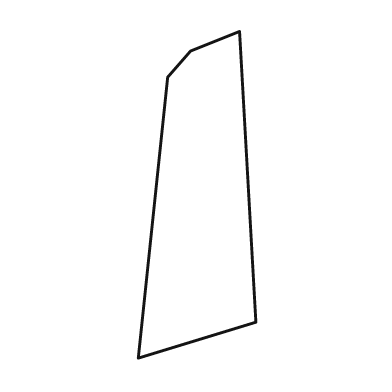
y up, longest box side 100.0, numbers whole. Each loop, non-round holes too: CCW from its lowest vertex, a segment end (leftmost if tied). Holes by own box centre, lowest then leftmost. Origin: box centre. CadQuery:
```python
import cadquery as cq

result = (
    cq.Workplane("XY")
    .moveTo(-18.0, -50.0)
    .lineTo(18.0, -39.0)
    .lineTo(13.0, 50.0)
    .lineTo(-2.0, 44.0)
    .lineTo(-9.0, 36.0)
    .close()
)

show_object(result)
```